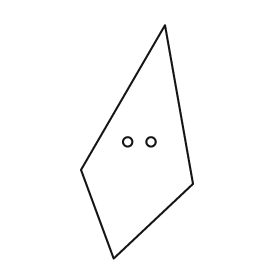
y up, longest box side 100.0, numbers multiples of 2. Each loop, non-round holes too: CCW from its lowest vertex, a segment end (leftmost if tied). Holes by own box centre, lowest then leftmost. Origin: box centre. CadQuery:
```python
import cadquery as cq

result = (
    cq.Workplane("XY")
    .moveTo(-10.0, -50.0)
    .lineTo(24.0, -18.0)
    .lineTo(12.0, 50.0)
    .lineTo(-24.0, -12.0)
    .close()
    .moveTo(-4.0, 0.0)
    .circle(2.0)
    .moveTo(6.0, 0.0)
    .circle(2.0)
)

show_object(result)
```